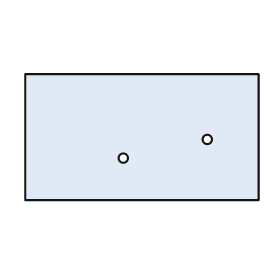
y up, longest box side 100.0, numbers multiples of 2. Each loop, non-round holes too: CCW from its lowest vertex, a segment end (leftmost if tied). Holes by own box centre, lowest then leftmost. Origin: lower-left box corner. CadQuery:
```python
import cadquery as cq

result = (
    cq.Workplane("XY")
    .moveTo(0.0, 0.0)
    .lineTo(100.0, 0.0)
    .lineTo(100.0, 54.0)
    .lineTo(0.0, 54.0)
    .close()
    .moveTo(42.0, 18.0)
    .circle(2.0)
    .moveTo(78.0, 26.0)
    .circle(2.0)
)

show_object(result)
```